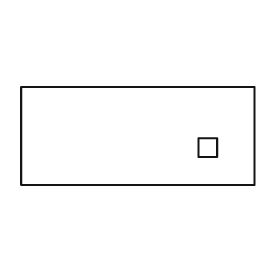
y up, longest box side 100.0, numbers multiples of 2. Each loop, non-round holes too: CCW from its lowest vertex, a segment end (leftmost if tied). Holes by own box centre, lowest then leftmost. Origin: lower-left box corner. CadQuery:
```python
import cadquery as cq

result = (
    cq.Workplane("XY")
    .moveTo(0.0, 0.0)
    .lineTo(100.0, 0.0)
    .lineTo(100.0, 42.0)
    .lineTo(0.0, 42.0)
    .close()
    .moveTo(76.0, 12.0)
    .lineTo(84.0, 12.0)
    .lineTo(84.0, 20.0)
    .lineTo(76.0, 20.0)
    .close()
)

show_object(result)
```